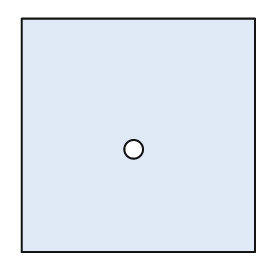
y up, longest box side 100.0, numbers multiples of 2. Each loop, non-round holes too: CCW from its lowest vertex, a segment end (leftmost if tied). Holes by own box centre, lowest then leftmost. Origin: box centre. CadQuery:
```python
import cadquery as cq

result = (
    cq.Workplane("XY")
    .moveTo(-50.0, -50.0)
    .lineTo(50.0, -50.0)
    .lineTo(50.0, 50.0)
    .lineTo(-50.0, 50.0)
    .close()
    .moveTo(-2.0, -6.0)
    .circle(4.0)
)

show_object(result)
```